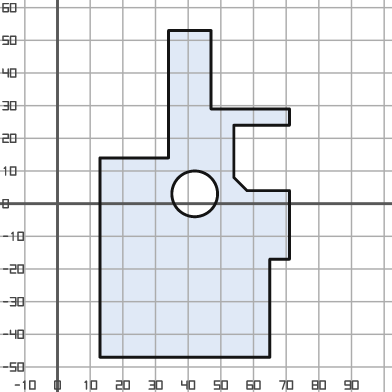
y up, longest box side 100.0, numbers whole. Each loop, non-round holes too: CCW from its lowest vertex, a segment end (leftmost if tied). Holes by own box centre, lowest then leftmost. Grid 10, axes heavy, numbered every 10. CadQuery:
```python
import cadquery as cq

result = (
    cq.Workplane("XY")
    .moveTo(13.0, -47.0)
    .lineTo(65.0, -47.0)
    .lineTo(65.0, -17.0)
    .lineTo(71.0, -17.0)
    .lineTo(71.0, 4.0)
    .lineTo(58.0, 4.0)
    .lineTo(54.0, 8.0)
    .lineTo(54.0, 24.0)
    .lineTo(71.0, 24.0)
    .lineTo(71.0, 29.0)
    .lineTo(47.0, 29.0)
    .lineTo(47.0, 53.0)
    .lineTo(34.0, 53.0)
    .lineTo(34.0, 14.0)
    .lineTo(13.0, 14.0)
    .close()
    .moveTo(42.0, 3.0)
    .circle(7.0)
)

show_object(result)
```